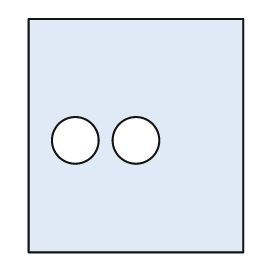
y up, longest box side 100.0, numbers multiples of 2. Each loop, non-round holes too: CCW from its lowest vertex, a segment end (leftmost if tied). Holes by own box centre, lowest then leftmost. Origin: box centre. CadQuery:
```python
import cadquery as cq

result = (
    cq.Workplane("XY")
    .moveTo(-46.0, -50.0)
    .lineTo(46.0, -50.0)
    .lineTo(46.0, 50.0)
    .lineTo(-46.0, 50.0)
    .close()
    .moveTo(-26.0, -2.0)
    .circle(10.0)
    .moveTo(0.0, -2.0)
    .circle(10.0)
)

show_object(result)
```